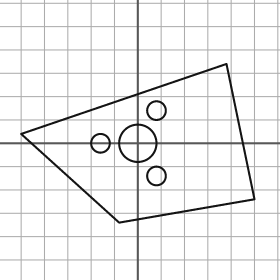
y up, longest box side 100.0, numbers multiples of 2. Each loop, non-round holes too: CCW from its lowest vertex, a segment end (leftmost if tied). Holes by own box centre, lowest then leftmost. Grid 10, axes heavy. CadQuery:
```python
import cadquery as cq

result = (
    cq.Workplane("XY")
    .moveTo(-8.0, -34.0)
    .lineTo(50.0, -24.0)
    .lineTo(38.0, 34.0)
    .lineTo(-50.0, 4.0)
    .close()
    .moveTo(8.0, -14.0)
    .circle(4.0)
    .moveTo(-16.0, 0.0)
    .circle(4.0)
    .moveTo(0.0, 0.0)
    .circle(8.0)
    .moveTo(8.0, 14.0)
    .circle(4.0)
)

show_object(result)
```